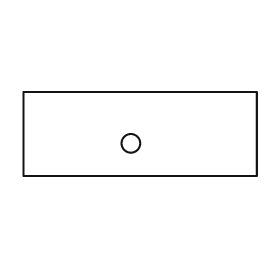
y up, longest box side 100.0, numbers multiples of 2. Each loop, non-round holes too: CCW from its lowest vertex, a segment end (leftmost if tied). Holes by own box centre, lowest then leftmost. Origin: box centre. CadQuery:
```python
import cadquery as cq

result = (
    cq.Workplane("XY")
    .moveTo(-50.0, -18.0)
    .lineTo(50.0, -18.0)
    .lineTo(50.0, 18.0)
    .lineTo(-50.0, 18.0)
    .close()
    .moveTo(-4.0, -4.0)
    .circle(4.0)
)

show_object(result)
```